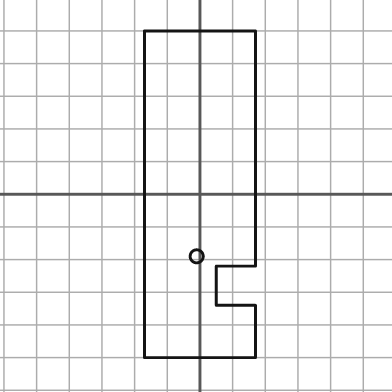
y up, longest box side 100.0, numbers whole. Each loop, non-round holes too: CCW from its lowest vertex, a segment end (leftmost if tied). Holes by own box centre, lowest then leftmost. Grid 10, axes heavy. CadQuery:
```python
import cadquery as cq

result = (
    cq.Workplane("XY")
    .moveTo(-17.0, -50.0)
    .lineTo(17.0, -50.0)
    .lineTo(17.0, -34.0)
    .lineTo(5.0, -34.0)
    .lineTo(5.0, -22.0)
    .lineTo(17.0, -22.0)
    .lineTo(17.0, 50.0)
    .lineTo(-17.0, 50.0)
    .close()
    .moveTo(-1.0, -19.0)
    .circle(2.0)
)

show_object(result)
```